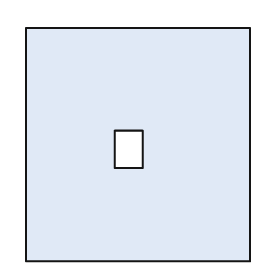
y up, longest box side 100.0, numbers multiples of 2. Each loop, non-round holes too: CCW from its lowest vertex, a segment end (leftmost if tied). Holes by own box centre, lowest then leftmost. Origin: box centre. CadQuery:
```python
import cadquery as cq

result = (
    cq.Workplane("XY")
    .moveTo(-48.0, -50.0)
    .lineTo(48.0, -50.0)
    .lineTo(48.0, 50.0)
    .lineTo(-48.0, 50.0)
    .close()
    .moveTo(-10.0, -10.0)
    .lineTo(2.0, -10.0)
    .lineTo(2.0, 6.0)
    .lineTo(-10.0, 6.0)
    .close()
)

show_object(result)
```